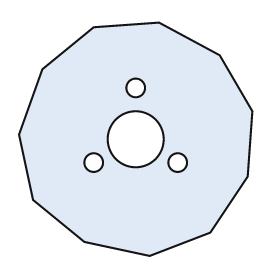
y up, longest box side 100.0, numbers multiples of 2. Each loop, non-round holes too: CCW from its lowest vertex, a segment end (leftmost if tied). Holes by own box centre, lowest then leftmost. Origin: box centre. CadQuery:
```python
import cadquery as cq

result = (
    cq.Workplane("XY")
    .moveTo(6.0, -50.0)
    .lineTo(32.0, -40.0)
    .lineTo(48.0, -16.0)
    .lineTo(50.0, 12.0)
    .lineTo(36.0, 36.0)
    .lineTo(10.0, 50.0)
    .lineTo(-18.0, 48.0)
    .lineTo(-40.0, 30.0)
    .lineTo(-50.0, 2.0)
    .lineTo(-44.0, -26.0)
    .lineTo(-22.0, -44.0)
    .close()
    .moveTo(-18.0, -10.0)
    .circle(4.0)
    .moveTo(18.0, -10.0)
    .circle(4.0)
    .moveTo(0.0, 0.0)
    .circle(12.0)
    .moveTo(0.0, 22.0)
    .circle(4.0)
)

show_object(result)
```